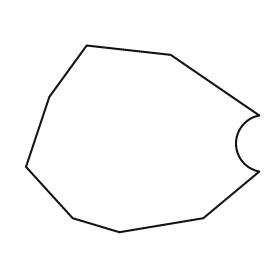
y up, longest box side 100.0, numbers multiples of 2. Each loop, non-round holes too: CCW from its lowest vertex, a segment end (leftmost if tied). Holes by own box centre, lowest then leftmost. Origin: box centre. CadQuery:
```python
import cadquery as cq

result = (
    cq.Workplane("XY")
    .moveTo(-10.0, -40.0)
    .lineTo(26.0, -34.0)
    .lineTo(50.0, -14.0)
    .threePointArc((40.0, -2.0), (50.0, 10.0))
    .lineTo(12.0, 36.0)
    .lineTo(-24.0, 40.0)
    .lineTo(-40.0, 18.0)
    .lineTo(-50.0, -12.0)
    .lineTo(-30.0, -34.0)
    .close()
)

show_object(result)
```